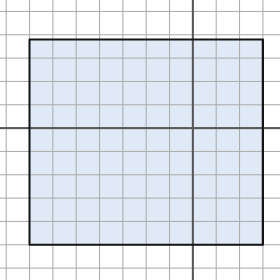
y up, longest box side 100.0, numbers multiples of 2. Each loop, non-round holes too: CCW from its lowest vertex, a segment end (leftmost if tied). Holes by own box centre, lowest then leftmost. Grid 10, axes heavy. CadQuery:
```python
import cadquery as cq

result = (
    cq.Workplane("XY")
    .moveTo(-70.0, -50.0)
    .lineTo(30.0, -50.0)
    .lineTo(30.0, 38.0)
    .lineTo(-70.0, 38.0)
    .close()
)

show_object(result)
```